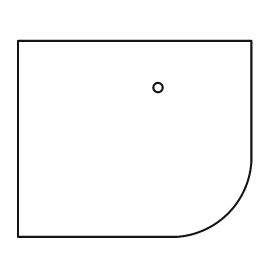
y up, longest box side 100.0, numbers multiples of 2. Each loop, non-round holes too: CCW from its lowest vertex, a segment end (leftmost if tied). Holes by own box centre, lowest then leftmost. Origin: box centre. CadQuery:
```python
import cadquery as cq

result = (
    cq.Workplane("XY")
    .moveTo(-50.0, -42.0)
    .lineTo(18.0, -42.0)
    .threePointArc((40.0, -32.0), (50.0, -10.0))
    .lineTo(50.0, 42.0)
    .lineTo(-50.0, 42.0)
    .close()
    .moveTo(10.0, 22.0)
    .circle(2.0)
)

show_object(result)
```